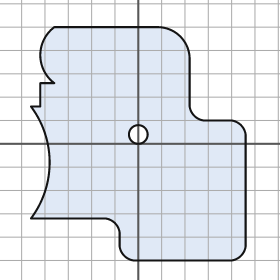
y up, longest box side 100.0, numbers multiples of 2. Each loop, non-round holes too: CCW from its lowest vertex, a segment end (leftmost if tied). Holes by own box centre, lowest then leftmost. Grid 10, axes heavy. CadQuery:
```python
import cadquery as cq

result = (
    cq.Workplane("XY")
    .moveTo(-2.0, -50.0)
    .lineTo(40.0, -50.0)
    .threePointArc((44.0, -48.0), (46.0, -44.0))
    .lineTo(46.0, 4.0)
    .threePointArc((44.0, 8.0), (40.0, 10.0))
    .lineTo(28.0, 10.0)
    .threePointArc((24.0, 12.0), (22.0, 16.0))
    .lineTo(22.0, 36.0)
    .threePointArc((18.0, 46.0), (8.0, 50.0))
    .lineTo(-36.0, 50.0)
    .threePointArc((-42.0, 38.0), (-36.0, 26.0))
    .lineTo(-42.0, 26.0)
    .lineTo(-42.0, 16.0)
    .lineTo(-46.0, 16.0)
    .threePointArc((-38.0, -8.0), (-46.0, -32.0))
    .lineTo(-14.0, -32.0)
    .threePointArc((-10.0, -34.0), (-8.0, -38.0))
    .lineTo(-8.0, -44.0)
    .threePointArc((-6.0, -48.0), (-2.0, -50.0))
    .close()
    .moveTo(0.0, 4.0)
    .circle(4.0)
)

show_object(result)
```